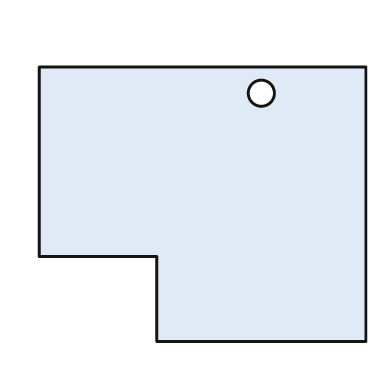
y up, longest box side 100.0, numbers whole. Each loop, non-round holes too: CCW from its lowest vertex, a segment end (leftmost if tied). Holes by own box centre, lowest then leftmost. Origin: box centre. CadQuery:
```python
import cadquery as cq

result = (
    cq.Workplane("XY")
    .moveTo(-14.0, -42.0)
    .lineTo(50.0, -42.0)
    .lineTo(50.0, 42.0)
    .lineTo(-50.0, 42.0)
    .lineTo(-50.0, -16.0)
    .lineTo(-14.0, -16.0)
    .close()
    .moveTo(18.0, 34.0)
    .circle(4.0)
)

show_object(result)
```